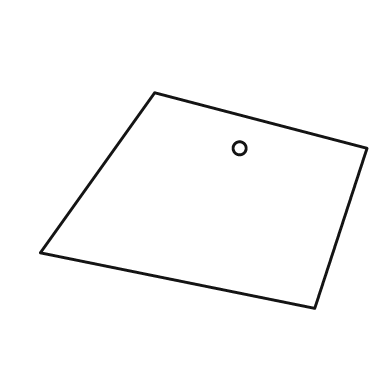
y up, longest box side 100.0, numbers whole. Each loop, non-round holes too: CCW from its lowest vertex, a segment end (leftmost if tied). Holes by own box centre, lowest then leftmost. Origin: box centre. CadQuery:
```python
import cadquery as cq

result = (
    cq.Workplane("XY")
    .moveTo(34.0, -33.0)
    .lineTo(50.0, 16.0)
    .lineTo(-15.0, 33.0)
    .lineTo(-50.0, -16.0)
    .close()
    .moveTo(11.0, 16.0)
    .circle(2.0)
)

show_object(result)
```